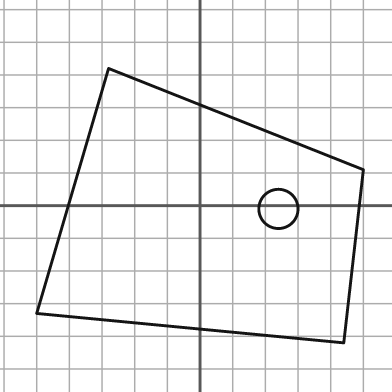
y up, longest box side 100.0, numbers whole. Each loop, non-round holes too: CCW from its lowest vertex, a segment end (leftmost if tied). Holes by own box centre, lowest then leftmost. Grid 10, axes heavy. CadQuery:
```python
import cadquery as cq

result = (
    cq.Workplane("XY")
    .moveTo(44.0, -42.0)
    .lineTo(50.0, 11.0)
    .lineTo(-28.0, 42.0)
    .lineTo(-50.0, -33.0)
    .close()
    .moveTo(24.0, -1.0)
    .circle(6.0)
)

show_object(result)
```